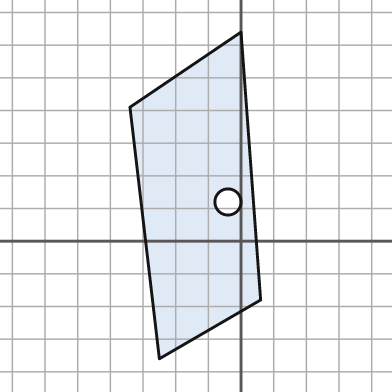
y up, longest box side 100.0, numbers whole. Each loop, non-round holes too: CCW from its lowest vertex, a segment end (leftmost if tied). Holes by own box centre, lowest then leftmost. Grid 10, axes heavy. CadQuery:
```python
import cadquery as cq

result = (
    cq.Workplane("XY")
    .moveTo(-25.0, -36.0)
    .lineTo(6.0, -18.0)
    .lineTo(0.0, 64.0)
    .lineTo(-34.0, 41.0)
    .close()
    .moveTo(-4.0, 12.0)
    .circle(4.0)
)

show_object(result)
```